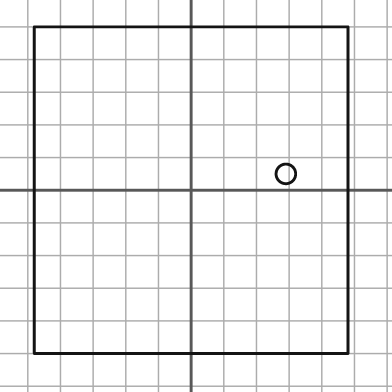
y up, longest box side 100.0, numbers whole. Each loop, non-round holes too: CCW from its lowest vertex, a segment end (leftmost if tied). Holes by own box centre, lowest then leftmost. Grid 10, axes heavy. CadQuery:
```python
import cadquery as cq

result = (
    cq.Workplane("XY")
    .moveTo(-48.0, -50.0)
    .lineTo(48.0, -50.0)
    .lineTo(48.0, 50.0)
    .lineTo(-48.0, 50.0)
    .close()
    .moveTo(29.0, 5.0)
    .circle(3.0)
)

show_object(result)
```